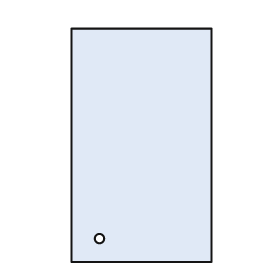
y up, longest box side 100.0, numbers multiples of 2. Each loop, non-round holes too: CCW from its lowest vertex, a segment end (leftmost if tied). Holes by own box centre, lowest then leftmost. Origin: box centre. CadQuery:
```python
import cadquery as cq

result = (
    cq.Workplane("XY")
    .moveTo(-30.0, -50.0)
    .lineTo(30.0, -50.0)
    .lineTo(30.0, 50.0)
    .lineTo(-30.0, 50.0)
    .close()
    .moveTo(-18.0, -40.0)
    .circle(2.0)
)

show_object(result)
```